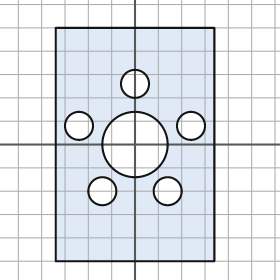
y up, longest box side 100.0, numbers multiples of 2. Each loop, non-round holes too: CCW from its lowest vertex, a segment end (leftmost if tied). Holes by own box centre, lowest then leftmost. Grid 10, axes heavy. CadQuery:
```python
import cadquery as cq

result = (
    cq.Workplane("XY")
    .moveTo(-34.0, -50.0)
    .lineTo(34.0, -50.0)
    .lineTo(34.0, 50.0)
    .lineTo(-34.0, 50.0)
    .close()
    .moveTo(-14.0, -20.0)
    .circle(6.0)
    .moveTo(14.0, -20.0)
    .circle(6.0)
    .moveTo(0.0, 0.0)
    .circle(14.0)
    .moveTo(-24.0, 8.0)
    .circle(6.0)
    .moveTo(24.0, 8.0)
    .circle(6.0)
    .moveTo(0.0, 26.0)
    .circle(6.0)
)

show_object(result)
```